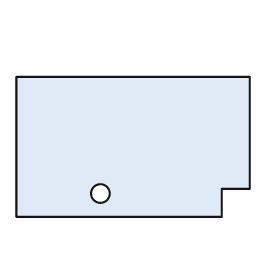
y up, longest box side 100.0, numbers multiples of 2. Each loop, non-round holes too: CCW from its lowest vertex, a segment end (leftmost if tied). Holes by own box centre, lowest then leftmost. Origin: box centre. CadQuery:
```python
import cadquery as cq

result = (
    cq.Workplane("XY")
    .moveTo(-50.0, -30.0)
    .lineTo(38.0, -30.0)
    .lineTo(38.0, -18.0)
    .lineTo(50.0, -18.0)
    .lineTo(50.0, 30.0)
    .lineTo(-50.0, 30.0)
    .close()
    .moveTo(-14.0, -20.0)
    .circle(4.0)
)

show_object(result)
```